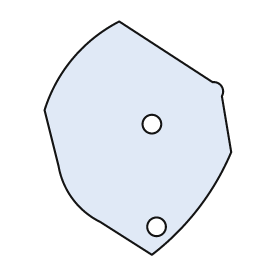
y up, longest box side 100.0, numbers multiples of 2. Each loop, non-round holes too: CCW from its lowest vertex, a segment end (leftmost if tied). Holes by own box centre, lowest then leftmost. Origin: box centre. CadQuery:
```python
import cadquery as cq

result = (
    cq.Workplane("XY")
    .moveTo(6.0, -50.0)
    .threePointArc((26.0, -30.0), (40.0, -6.0))
    .lineTo(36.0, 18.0)
    .threePointArc((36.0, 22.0), (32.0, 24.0))
    .lineTo(-8.0, 50.0)
    .threePointArc((-28.0, 34.0), (-40.0, 12.0))
    .lineTo(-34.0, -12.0)
    .threePointArc((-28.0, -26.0), (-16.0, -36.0))
    .close()
    .moveTo(8.0, -38.0)
    .circle(4.0)
    .moveTo(6.0, 6.0)
    .circle(4.0)
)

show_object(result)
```